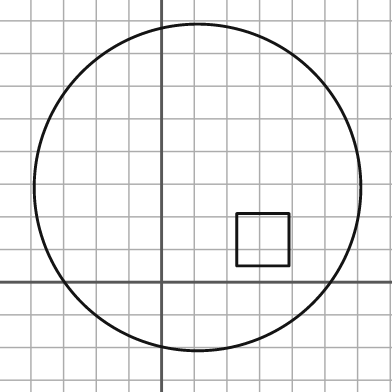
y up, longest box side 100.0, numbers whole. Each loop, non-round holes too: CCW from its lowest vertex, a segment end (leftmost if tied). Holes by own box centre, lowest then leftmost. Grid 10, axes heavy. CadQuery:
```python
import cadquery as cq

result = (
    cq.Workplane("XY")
    .moveTo(11.0, 29.0)
    .circle(50.0)
    .moveTo(23.0, 5.0)
    .lineTo(39.0, 5.0)
    .lineTo(39.0, 21.0)
    .lineTo(23.0, 21.0)
    .close()
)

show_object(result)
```